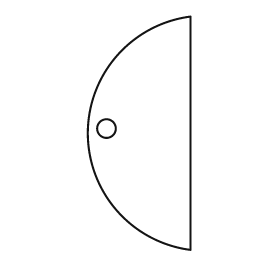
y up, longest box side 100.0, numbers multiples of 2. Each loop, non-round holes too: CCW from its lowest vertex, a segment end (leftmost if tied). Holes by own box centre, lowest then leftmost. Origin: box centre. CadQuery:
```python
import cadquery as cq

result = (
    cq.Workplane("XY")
    .moveTo(22.0, -50.0)
    .lineTo(22.0, 50.0)
    .threePointArc((-22.0, 0.0), (22.0, -50.0))
    .close()
    .moveTo(-14.0, 2.0)
    .circle(4.0)
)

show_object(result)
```